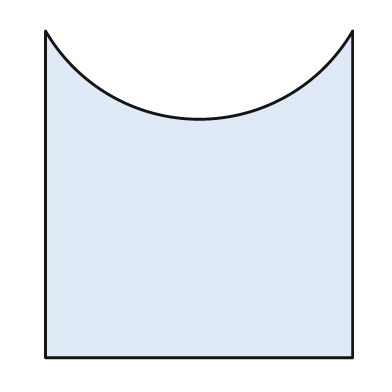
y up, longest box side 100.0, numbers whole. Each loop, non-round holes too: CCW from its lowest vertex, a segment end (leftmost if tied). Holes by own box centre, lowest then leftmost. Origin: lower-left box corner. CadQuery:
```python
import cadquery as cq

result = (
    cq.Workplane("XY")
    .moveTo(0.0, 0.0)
    .lineTo(94.0, 0.0)
    .lineTo(94.0, 100.0)
    .threePointArc((47.0, 73.0), (0.0, 100.0))
    .close()
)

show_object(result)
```